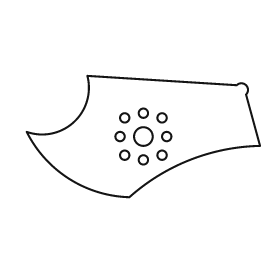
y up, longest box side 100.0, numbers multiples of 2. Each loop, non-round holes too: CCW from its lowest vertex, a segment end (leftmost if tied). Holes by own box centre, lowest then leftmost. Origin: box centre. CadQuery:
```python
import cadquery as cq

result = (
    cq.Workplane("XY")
    .moveTo(-6.0, -26.0)
    .threePointArc((20.0, -10.0), (50.0, -4.0))
    .lineTo(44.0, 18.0)
    .threePointArc((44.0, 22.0), (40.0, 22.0))
    .lineTo(-24.0, 26.0)
    .threePointArc((-30.0, 6.0), (-50.0, 2.0))
    .threePointArc((-32.0, -18.0), (-6.0, -26.0))
    .close()
    .moveTo(0.0, -10.0)
    .circle(2.0)
    .moveTo(-8.0, -8.0)
    .circle(2.0)
    .moveTo(8.0, -8.0)
    .circle(2.0)
    .moveTo(-10.0, 0.0)
    .circle(2.0)
    .moveTo(0.0, 0.0)
    .circle(4.0)
    .moveTo(10.0, 0.0)
    .circle(2.0)
    .moveTo(-8.0, 8.0)
    .circle(2.0)
    .moveTo(8.0, 8.0)
    .circle(2.0)
    .moveTo(0.0, 10.0)
    .circle(2.0)
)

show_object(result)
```